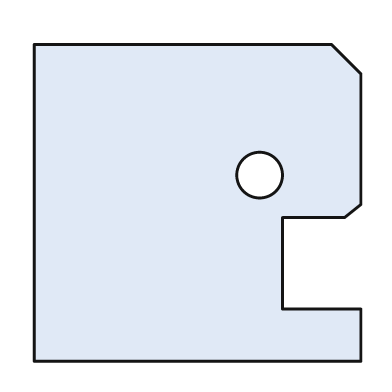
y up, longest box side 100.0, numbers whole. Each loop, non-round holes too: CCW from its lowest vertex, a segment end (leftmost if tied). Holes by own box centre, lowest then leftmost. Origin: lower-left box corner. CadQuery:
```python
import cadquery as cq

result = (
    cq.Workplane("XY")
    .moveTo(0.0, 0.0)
    .lineTo(100.0, 0.0)
    .lineTo(100.0, 16.0)
    .lineTo(76.0, 16.0)
    .lineTo(76.0, 44.0)
    .lineTo(95.0, 44.0)
    .lineTo(100.0, 48.0)
    .lineTo(100.0, 88.0)
    .lineTo(91.0, 97.0)
    .lineTo(0.0, 97.0)
    .close()
    .moveTo(69.0, 57.0)
    .circle(7.0)
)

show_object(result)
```